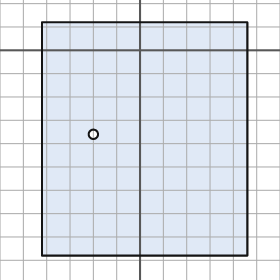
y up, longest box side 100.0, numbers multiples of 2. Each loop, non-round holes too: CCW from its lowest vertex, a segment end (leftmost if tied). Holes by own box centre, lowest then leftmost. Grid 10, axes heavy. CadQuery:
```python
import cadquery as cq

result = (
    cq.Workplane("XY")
    .moveTo(-42.0, -88.0)
    .lineTo(46.0, -88.0)
    .lineTo(46.0, 12.0)
    .lineTo(-42.0, 12.0)
    .close()
    .moveTo(-20.0, -36.0)
    .circle(2.0)
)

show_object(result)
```